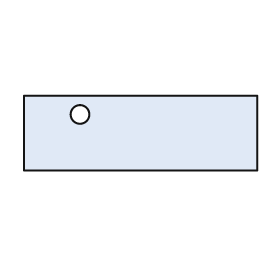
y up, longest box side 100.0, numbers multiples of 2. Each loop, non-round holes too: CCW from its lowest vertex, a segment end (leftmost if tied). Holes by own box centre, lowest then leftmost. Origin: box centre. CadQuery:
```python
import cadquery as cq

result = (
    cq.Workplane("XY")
    .moveTo(-50.0, -16.0)
    .lineTo(50.0, -16.0)
    .lineTo(50.0, 16.0)
    .lineTo(-50.0, 16.0)
    .close()
    .moveTo(-26.0, 8.0)
    .circle(4.0)
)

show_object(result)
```